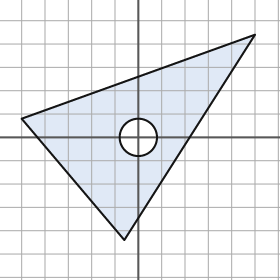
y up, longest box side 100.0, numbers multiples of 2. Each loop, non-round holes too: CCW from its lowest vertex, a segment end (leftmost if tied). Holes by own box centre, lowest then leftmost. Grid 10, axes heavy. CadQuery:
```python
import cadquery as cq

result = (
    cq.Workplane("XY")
    .moveTo(-6.0, -44.0)
    .lineTo(50.0, 44.0)
    .lineTo(-50.0, 8.0)
    .close()
    .moveTo(0.0, 0.0)
    .circle(8.0)
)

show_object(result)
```